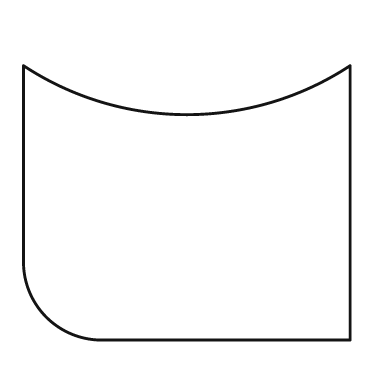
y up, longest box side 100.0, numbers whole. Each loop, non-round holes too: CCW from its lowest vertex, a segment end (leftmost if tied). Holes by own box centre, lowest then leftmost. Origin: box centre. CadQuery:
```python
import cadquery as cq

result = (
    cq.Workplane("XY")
    .moveTo(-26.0, -42.0)
    .lineTo(50.0, -42.0)
    .lineTo(50.0, 42.0)
    .threePointArc((0.0, 27.0), (-50.0, 42.0))
    .lineTo(-50.0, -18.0)
    .threePointArc((-43.0, -35.0), (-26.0, -42.0))
    .close()
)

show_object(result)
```